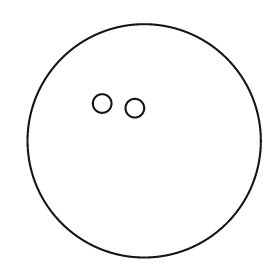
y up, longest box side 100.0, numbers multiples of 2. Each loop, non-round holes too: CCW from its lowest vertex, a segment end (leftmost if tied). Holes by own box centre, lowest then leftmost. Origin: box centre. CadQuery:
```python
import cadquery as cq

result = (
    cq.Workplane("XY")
    .moveTo(0.0, 0.0)
    .circle(50.0)
    .moveTo(-4.0, 14.0)
    .circle(4.0)
    .moveTo(-18.0, 16.0)
    .circle(4.0)
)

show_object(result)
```